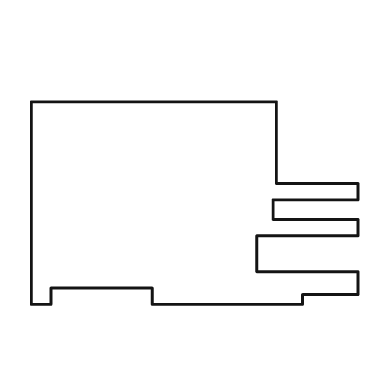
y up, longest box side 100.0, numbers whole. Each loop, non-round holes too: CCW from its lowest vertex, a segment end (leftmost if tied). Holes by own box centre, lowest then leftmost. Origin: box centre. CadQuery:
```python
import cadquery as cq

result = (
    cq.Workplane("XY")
    .moveTo(-50.0, -31.0)
    .lineTo(-44.0, -31.0)
    .lineTo(-44.0, -26.0)
    .lineTo(-13.0, -26.0)
    .lineTo(-13.0, -31.0)
    .lineTo(33.0, -31.0)
    .lineTo(33.0, -28.0)
    .lineTo(50.0, -28.0)
    .lineTo(50.0, -21.0)
    .lineTo(19.0, -21.0)
    .lineTo(19.0, -10.0)
    .lineTo(50.0, -10.0)
    .lineTo(50.0, -5.0)
    .lineTo(24.0, -5.0)
    .lineTo(24.0, 1.0)
    .lineTo(50.0, 1.0)
    .lineTo(50.0, 6.0)
    .lineTo(25.0, 6.0)
    .lineTo(25.0, 31.0)
    .lineTo(-50.0, 31.0)
    .close()
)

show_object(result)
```